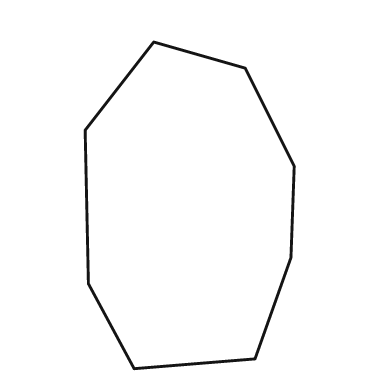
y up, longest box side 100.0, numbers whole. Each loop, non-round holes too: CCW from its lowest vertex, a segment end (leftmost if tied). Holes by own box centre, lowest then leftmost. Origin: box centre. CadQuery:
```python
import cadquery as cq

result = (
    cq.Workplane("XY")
    .moveTo(-17.0, -50.0)
    .lineTo(20.0, -47.0)
    .lineTo(31.0, -16.0)
    .lineTo(32.0, 12.0)
    .lineTo(17.0, 42.0)
    .lineTo(-11.0, 50.0)
    .lineTo(-32.0, 23.0)
    .lineTo(-31.0, -24.0)
    .close()
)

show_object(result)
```